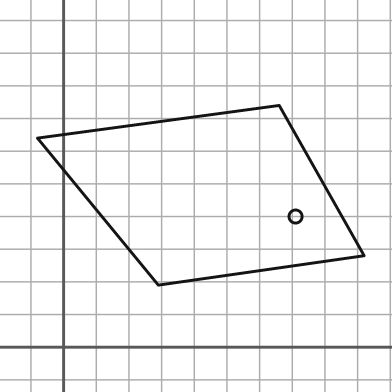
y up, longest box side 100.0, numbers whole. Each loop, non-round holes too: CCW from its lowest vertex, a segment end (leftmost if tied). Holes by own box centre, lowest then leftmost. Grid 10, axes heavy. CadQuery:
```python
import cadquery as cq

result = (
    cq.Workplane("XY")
    .moveTo(29.0, 19.0)
    .lineTo(92.0, 28.0)
    .lineTo(66.0, 74.0)
    .lineTo(-8.0, 64.0)
    .close()
    .moveTo(71.0, 40.0)
    .circle(2.0)
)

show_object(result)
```